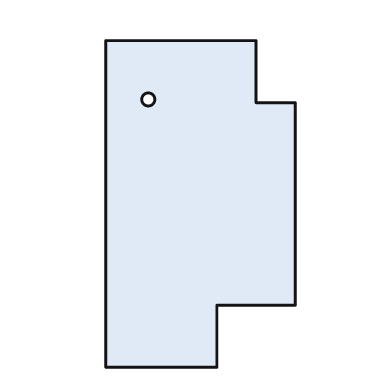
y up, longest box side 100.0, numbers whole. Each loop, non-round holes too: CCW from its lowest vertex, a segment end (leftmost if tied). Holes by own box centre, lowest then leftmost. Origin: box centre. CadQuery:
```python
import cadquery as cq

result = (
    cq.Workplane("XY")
    .moveTo(-29.0, -50.0)
    .lineTo(5.0, -50.0)
    .lineTo(5.0, -31.0)
    .lineTo(29.0, -31.0)
    .lineTo(29.0, 31.0)
    .lineTo(17.0, 31.0)
    .lineTo(17.0, 50.0)
    .lineTo(-29.0, 50.0)
    .close()
    .moveTo(-16.0, 32.0)
    .circle(2.0)
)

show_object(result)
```